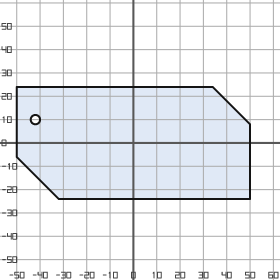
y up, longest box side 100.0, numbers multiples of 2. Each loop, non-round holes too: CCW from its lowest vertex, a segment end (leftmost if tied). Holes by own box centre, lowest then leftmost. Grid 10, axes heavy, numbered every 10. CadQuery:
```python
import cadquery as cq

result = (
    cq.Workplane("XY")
    .moveTo(-32.0, -24.0)
    .lineTo(50.0, -24.0)
    .lineTo(50.0, 8.0)
    .lineTo(34.0, 24.0)
    .lineTo(-50.0, 24.0)
    .lineTo(-50.0, -6.0)
    .close()
    .moveTo(-42.0, 10.0)
    .circle(2.0)
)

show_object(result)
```